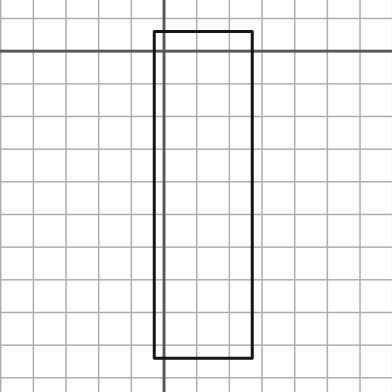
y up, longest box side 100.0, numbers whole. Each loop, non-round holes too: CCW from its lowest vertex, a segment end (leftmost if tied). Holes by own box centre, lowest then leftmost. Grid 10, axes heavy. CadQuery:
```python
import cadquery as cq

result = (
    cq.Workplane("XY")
    .moveTo(-3.0, -94.0)
    .lineTo(27.0, -94.0)
    .lineTo(27.0, 6.0)
    .lineTo(-3.0, 6.0)
    .close()
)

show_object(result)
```